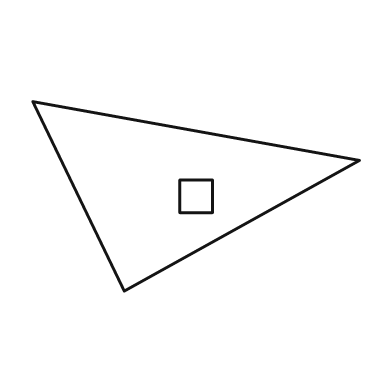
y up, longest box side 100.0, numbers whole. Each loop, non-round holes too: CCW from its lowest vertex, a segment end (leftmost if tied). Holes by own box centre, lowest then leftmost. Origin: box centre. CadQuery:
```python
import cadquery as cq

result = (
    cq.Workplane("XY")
    .moveTo(-22.0, -29.0)
    .lineTo(50.0, 11.0)
    .lineTo(-50.0, 29.0)
    .close()
    .moveTo(-5.0, -5.0)
    .lineTo(5.0, -5.0)
    .lineTo(5.0, 5.0)
    .lineTo(-5.0, 5.0)
    .close()
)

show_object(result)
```